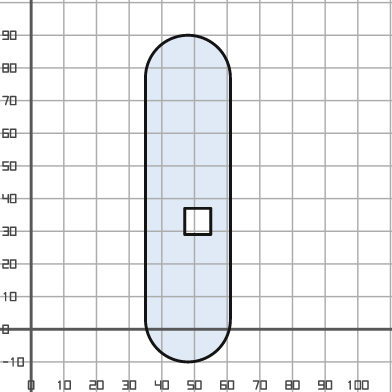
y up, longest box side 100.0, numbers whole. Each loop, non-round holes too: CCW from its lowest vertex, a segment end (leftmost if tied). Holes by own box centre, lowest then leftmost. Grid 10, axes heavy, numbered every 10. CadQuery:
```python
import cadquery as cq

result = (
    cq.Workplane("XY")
    .moveTo(35.0, 3.0)
    .threePointArc((48.0, -10.0), (61.0, 3.0))
    .lineTo(61.0, 77.0)
    .threePointArc((48.0, 90.0), (35.0, 77.0))
    .close()
    .moveTo(47.0, 29.0)
    .lineTo(55.0, 29.0)
    .lineTo(55.0, 37.0)
    .lineTo(47.0, 37.0)
    .close()
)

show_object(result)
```